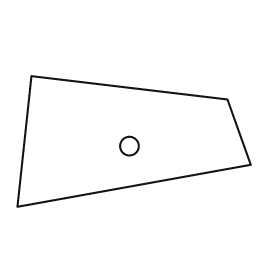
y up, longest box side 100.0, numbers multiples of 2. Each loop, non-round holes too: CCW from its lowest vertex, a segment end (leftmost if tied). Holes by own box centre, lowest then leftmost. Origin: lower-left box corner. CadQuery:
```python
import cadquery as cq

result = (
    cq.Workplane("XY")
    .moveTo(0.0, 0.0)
    .lineTo(100.0, 18.0)
    .lineTo(90.0, 46.0)
    .lineTo(6.0, 56.0)
    .close()
    .moveTo(48.0, 26.0)
    .circle(4.0)
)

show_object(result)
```